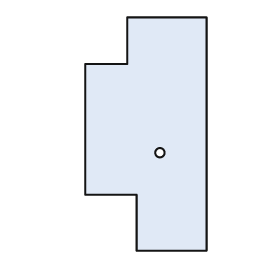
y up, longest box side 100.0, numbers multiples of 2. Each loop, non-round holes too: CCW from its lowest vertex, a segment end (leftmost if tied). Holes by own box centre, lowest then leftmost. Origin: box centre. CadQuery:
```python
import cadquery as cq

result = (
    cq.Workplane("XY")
    .moveTo(-4.0, -50.0)
    .lineTo(26.0, -50.0)
    .lineTo(26.0, 50.0)
    .lineTo(-8.0, 50.0)
    .lineTo(-8.0, 30.0)
    .lineTo(-26.0, 30.0)
    .lineTo(-26.0, -26.0)
    .lineTo(-4.0, -26.0)
    .close()
    .moveTo(6.0, -8.0)
    .circle(2.0)
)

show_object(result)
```